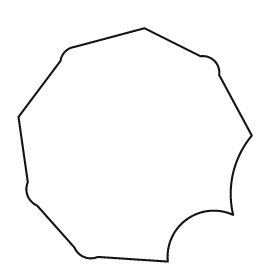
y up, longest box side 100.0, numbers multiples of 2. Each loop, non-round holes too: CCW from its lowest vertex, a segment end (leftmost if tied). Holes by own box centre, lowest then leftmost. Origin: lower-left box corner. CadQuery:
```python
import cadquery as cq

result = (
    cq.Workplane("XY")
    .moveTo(64.0, 0.0)
    .threePointArc((72.0, 18.0), (92.0, 20.0))
    .threePointArc((92.0, 38.0), (100.0, 54.0))
    .lineTo(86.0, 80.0)
    .threePointArc((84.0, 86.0), (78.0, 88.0))
    .lineTo(54.0, 100.0)
    .lineTo(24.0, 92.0)
    .threePointArc((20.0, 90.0), (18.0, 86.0))
    .lineTo(0.0, 62.0)
    .lineTo(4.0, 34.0)
    .threePointArc((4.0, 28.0), (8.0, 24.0))
    .lineTo(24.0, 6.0)
    .threePointArc((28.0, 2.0), (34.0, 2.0))
    .close()
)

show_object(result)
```